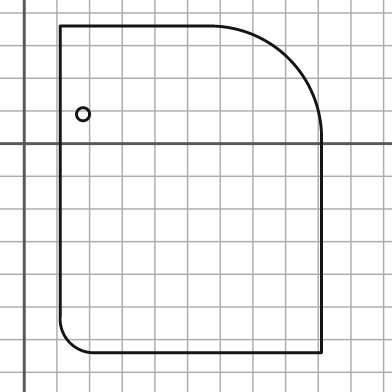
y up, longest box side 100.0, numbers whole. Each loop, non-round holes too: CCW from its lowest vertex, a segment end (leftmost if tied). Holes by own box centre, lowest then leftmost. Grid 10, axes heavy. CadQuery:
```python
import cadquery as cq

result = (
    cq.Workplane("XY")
    .moveTo(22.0, -64.0)
    .lineTo(91.0, -64.0)
    .lineTo(91.0, 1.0)
    .threePointArc((81.0, 26.0), (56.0, 36.0))
    .lineTo(11.0, 36.0)
    .lineTo(11.0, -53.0)
    .threePointArc((14.0, -61.0), (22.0, -64.0))
    .close()
    .moveTo(18.0, 9.0)
    .circle(2.0)
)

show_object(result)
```